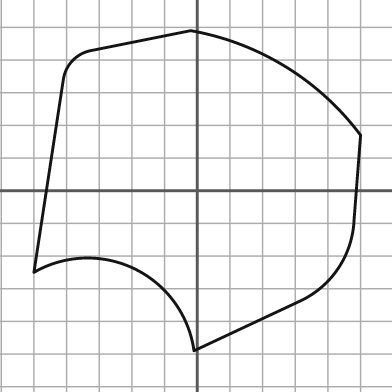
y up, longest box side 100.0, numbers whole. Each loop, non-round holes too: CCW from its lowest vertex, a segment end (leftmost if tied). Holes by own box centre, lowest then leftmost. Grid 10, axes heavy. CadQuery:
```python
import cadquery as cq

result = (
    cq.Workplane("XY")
    .moveTo(-1.0, -49.0)
    .lineTo(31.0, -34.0)
    .threePointArc((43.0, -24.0), (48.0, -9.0))
    .lineTo(50.0, 17.0)
    .threePointArc((27.0, 38.0), (-2.0, 49.0))
    .lineTo(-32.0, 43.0)
    .threePointArc((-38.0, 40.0), (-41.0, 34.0))
    .lineTo(-50.0, -25.0)
    .threePointArc((-19.0, -24.0), (-1.0, -49.0))
    .close()
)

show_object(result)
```